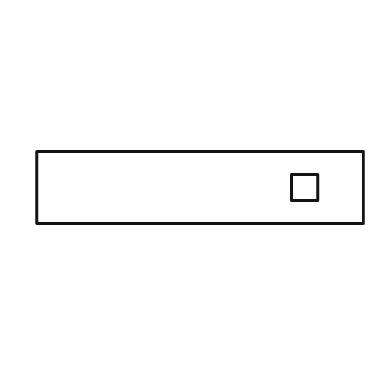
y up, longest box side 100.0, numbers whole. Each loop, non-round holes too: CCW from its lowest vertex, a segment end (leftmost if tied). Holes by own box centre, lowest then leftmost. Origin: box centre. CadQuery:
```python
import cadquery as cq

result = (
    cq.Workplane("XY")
    .moveTo(-50.0, -11.0)
    .lineTo(50.0, -11.0)
    .lineTo(50.0, 11.0)
    .lineTo(-50.0, 11.0)
    .close()
    .moveTo(28.0, -4.0)
    .lineTo(36.0, -4.0)
    .lineTo(36.0, 4.0)
    .lineTo(28.0, 4.0)
    .close()
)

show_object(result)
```